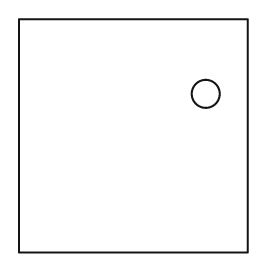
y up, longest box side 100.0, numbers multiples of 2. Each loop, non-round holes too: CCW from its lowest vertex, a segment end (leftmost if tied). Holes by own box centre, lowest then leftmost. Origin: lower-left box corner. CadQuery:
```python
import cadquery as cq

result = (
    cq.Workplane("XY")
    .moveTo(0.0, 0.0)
    .lineTo(98.0, 0.0)
    .lineTo(98.0, 100.0)
    .lineTo(0.0, 100.0)
    .close()
    .moveTo(80.0, 68.0)
    .circle(6.0)
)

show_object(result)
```